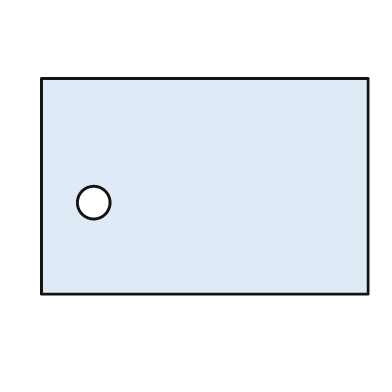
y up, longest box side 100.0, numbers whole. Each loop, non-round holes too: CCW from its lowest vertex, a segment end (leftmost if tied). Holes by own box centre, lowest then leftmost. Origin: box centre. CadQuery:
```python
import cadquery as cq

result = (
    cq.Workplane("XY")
    .moveTo(-50.0, -33.0)
    .lineTo(50.0, -33.0)
    .lineTo(50.0, 33.0)
    .lineTo(-50.0, 33.0)
    .close()
    .moveTo(-34.0, -5.0)
    .circle(5.0)
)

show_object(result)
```